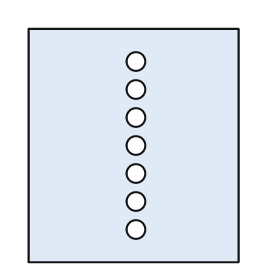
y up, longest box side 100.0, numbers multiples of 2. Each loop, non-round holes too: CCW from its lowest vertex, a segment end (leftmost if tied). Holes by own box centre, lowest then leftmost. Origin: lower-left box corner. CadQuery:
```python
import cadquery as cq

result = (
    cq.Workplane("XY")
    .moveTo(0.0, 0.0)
    .lineTo(90.0, 0.0)
    .lineTo(90.0, 100.0)
    .lineTo(0.0, 100.0)
    .close()
    .moveTo(46.0, 14.0)
    .circle(4.0)
    .moveTo(46.0, 26.0)
    .circle(4.0)
    .moveTo(46.0, 38.0)
    .circle(4.0)
    .moveTo(46.0, 50.0)
    .circle(4.0)
    .moveTo(46.0, 62.0)
    .circle(4.0)
    .moveTo(46.0, 74.0)
    .circle(4.0)
    .moveTo(46.0, 86.0)
    .circle(4.0)
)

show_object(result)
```